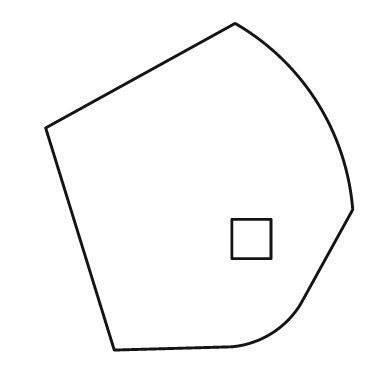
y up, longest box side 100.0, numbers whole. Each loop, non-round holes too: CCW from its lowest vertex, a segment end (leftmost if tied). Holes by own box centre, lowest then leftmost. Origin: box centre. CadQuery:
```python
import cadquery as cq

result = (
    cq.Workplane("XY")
    .moveTo(-26.0, -50.0)
    .lineTo(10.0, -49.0)
    .threePointArc((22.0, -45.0), (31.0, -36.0))
    .lineTo(47.0, -7.0)
    .threePointArc((36.0, 26.0), (11.0, 50.0))
    .lineTo(-47.0, 18.0)
    .close()
    .moveTo(10.0, -22.0)
    .lineTo(22.0, -22.0)
    .lineTo(22.0, -10.0)
    .lineTo(10.0, -10.0)
    .close()
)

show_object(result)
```